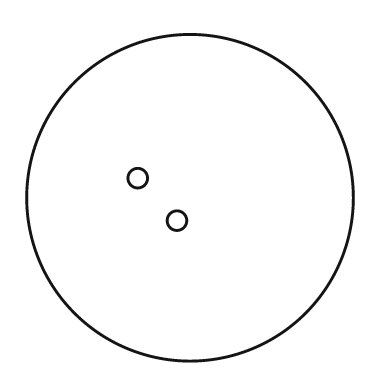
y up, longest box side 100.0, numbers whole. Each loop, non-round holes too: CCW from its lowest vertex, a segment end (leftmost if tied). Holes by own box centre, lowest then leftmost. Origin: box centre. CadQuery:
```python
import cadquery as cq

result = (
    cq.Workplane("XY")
    .moveTo(0.0, 0.0)
    .circle(50.0)
    .moveTo(-4.0, -7.0)
    .circle(3.0)
    .moveTo(-16.0, 6.0)
    .circle(3.0)
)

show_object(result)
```